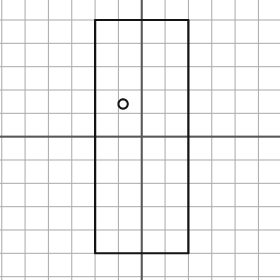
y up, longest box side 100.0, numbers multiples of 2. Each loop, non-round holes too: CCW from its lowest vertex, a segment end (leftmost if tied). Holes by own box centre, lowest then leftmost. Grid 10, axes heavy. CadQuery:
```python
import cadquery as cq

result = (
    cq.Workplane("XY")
    .moveTo(-20.0, -50.0)
    .lineTo(20.0, -50.0)
    .lineTo(20.0, 50.0)
    .lineTo(-20.0, 50.0)
    .close()
    .moveTo(-8.0, 14.0)
    .circle(2.0)
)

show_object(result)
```